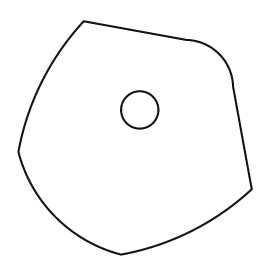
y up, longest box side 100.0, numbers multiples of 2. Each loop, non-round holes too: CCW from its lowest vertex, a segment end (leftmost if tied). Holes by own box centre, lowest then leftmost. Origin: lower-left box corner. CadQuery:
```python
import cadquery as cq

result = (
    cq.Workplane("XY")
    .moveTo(44.0, 0.0)
    .threePointArc((74.0, 10.0), (100.0, 28.0))
    .lineTo(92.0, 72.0)
    .threePointArc((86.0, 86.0), (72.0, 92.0))
    .lineTo(28.0, 100.0)
    .threePointArc((10.0, 74.0), (0.0, 44.0))
    .threePointArc((16.0, 16.0), (44.0, 0.0))
    .close()
    .moveTo(52.0, 62.0)
    .circle(8.0)
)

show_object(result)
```